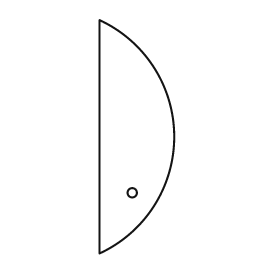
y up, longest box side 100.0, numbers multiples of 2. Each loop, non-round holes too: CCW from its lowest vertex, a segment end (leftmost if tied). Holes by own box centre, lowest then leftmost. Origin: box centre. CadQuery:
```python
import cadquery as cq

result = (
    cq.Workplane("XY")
    .moveTo(-16.0, -50.0)
    .threePointArc((16.0, 0.0), (-16.0, 50.0))
    .close()
    .moveTo(-2.0, -24.0)
    .circle(2.0)
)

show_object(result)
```